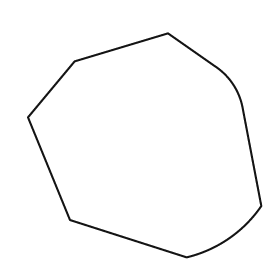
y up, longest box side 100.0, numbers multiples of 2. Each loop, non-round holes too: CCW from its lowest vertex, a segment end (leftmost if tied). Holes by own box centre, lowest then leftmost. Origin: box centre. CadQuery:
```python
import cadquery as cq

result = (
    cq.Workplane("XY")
    .moveTo(18.0, -48.0)
    .threePointArc((36.0, -40.0), (50.0, -26.0))
    .lineTo(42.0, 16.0)
    .threePointArc((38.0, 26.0), (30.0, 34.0))
    .lineTo(10.0, 48.0)
    .lineTo(-30.0, 36.0)
    .lineTo(-50.0, 12.0)
    .lineTo(-32.0, -32.0)
    .close()
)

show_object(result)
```